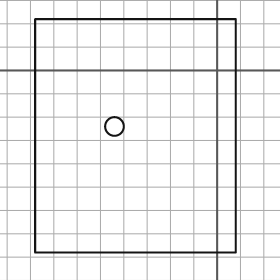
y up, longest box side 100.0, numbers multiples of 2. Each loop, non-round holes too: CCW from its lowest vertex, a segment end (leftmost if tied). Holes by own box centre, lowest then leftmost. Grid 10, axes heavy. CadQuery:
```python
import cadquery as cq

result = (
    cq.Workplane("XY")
    .moveTo(-78.0, -78.0)
    .lineTo(8.0, -78.0)
    .lineTo(8.0, 22.0)
    .lineTo(-78.0, 22.0)
    .close()
    .moveTo(-44.0, -24.0)
    .circle(4.0)
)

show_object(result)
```